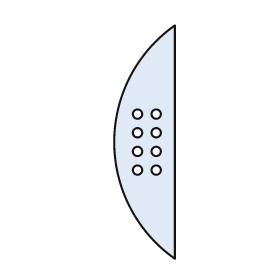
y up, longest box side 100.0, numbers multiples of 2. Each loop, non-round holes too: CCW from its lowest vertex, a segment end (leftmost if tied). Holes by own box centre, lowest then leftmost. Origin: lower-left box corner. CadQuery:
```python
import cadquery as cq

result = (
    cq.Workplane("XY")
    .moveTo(26.0, 0.0)
    .lineTo(26.0, 100.0)
    .threePointArc((0.0, 50.0), (26.0, 0.0))
    .close()
    .moveTo(10.0, 38.0)
    .circle(2.0)
    .moveTo(18.0, 38.0)
    .circle(2.0)
    .moveTo(10.0, 46.0)
    .circle(2.0)
    .moveTo(18.0, 46.0)
    .circle(2.0)
    .moveTo(10.0, 54.0)
    .circle(2.0)
    .moveTo(18.0, 54.0)
    .circle(2.0)
    .moveTo(10.0, 62.0)
    .circle(2.0)
    .moveTo(18.0, 62.0)
    .circle(2.0)
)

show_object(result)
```